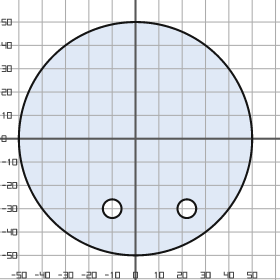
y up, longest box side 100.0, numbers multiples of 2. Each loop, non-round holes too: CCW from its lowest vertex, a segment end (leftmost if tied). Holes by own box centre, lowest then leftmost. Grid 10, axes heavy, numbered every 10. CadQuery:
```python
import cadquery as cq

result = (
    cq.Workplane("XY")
    .moveTo(0.0, 0.0)
    .circle(50.0)
    .moveTo(-10.0, -30.0)
    .circle(4.0)
    .moveTo(22.0, -30.0)
    .circle(4.0)
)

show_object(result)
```